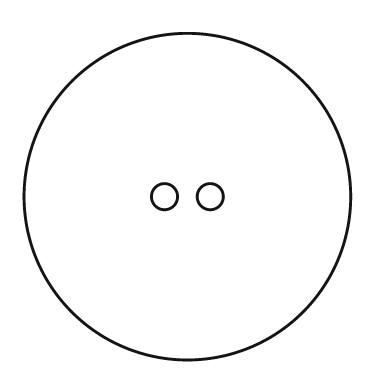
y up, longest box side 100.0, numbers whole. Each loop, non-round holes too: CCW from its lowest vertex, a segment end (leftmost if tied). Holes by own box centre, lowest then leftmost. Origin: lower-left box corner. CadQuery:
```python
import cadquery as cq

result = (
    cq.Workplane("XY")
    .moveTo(50.0, 50.0)
    .circle(50.0)
    .moveTo(43.0, 50.0)
    .circle(4.0)
    .moveTo(57.0, 50.0)
    .circle(4.0)
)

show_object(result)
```